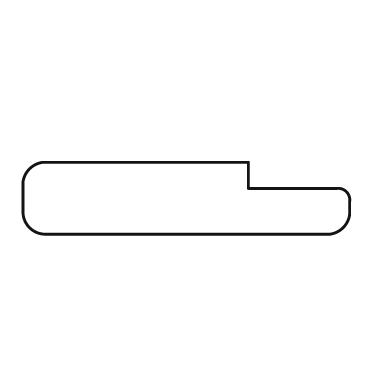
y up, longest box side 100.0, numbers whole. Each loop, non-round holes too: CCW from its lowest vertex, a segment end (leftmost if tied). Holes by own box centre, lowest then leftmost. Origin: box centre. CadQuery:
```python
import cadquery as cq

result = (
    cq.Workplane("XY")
    .moveTo(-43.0, -11.0)
    .lineTo(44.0, -11.0)
    .threePointArc((48.0, -9.0), (50.0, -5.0))
    .lineTo(50.0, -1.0)
    .threePointArc((49.0, 2.0), (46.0, 3.0))
    .lineTo(19.0, 3.0)
    .lineTo(19.0, 11.0)
    .lineTo(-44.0, 11.0)
    .threePointArc((-48.0, 9.0), (-50.0, 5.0))
    .lineTo(-50.0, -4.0)
    .threePointArc((-48.0, -9.0), (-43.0, -11.0))
    .close()
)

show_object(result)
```